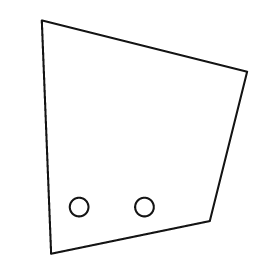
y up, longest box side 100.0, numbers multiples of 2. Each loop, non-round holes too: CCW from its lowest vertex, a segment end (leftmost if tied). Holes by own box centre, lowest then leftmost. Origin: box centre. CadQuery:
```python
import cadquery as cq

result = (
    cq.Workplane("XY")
    .moveTo(-40.0, -50.0)
    .lineTo(28.0, -36.0)
    .lineTo(44.0, 28.0)
    .lineTo(-44.0, 50.0)
    .close()
    .moveTo(-28.0, -30.0)
    .circle(4.0)
    .moveTo(0.0, -30.0)
    .circle(4.0)
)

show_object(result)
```